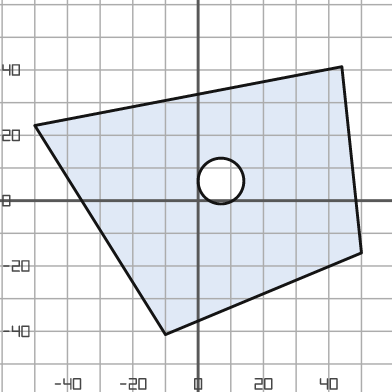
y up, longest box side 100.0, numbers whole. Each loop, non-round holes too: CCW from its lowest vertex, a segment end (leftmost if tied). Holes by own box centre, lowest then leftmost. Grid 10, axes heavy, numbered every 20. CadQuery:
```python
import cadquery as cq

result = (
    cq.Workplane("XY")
    .moveTo(-10.0, -41.0)
    .lineTo(50.0, -16.0)
    .lineTo(44.0, 41.0)
    .lineTo(-50.0, 23.0)
    .close()
    .moveTo(7.0, 6.0)
    .circle(7.0)
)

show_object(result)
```